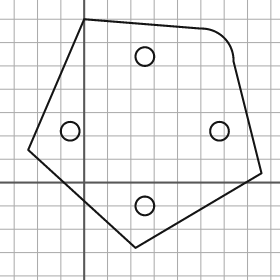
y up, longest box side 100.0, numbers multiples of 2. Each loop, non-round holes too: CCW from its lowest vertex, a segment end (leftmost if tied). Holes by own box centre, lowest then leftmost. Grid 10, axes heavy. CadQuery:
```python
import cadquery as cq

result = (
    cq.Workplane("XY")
    .moveTo(22.0, -28.0)
    .lineTo(76.0, 4.0)
    .lineTo(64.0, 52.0)
    .threePointArc((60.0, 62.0), (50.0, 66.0))
    .lineTo(0.0, 70.0)
    .lineTo(-24.0, 14.0)
    .close()
    .moveTo(26.0, -10.0)
    .circle(4.0)
    .moveTo(-6.0, 22.0)
    .circle(4.0)
    .moveTo(58.0, 22.0)
    .circle(4.0)
    .moveTo(26.0, 54.0)
    .circle(4.0)
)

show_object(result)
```